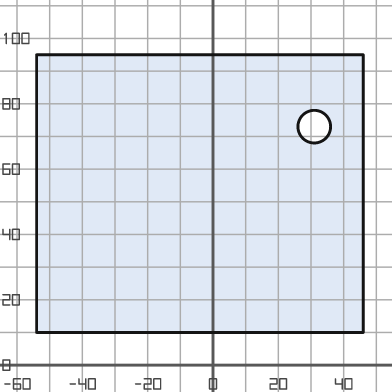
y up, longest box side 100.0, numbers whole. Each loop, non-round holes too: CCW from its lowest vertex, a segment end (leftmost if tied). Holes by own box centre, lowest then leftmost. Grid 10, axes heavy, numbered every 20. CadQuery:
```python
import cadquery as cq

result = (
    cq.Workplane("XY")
    .moveTo(-54.0, 10.0)
    .lineTo(46.0, 10.0)
    .lineTo(46.0, 95.0)
    .lineTo(-54.0, 95.0)
    .close()
    .moveTo(31.0, 73.0)
    .circle(5.0)
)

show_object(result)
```